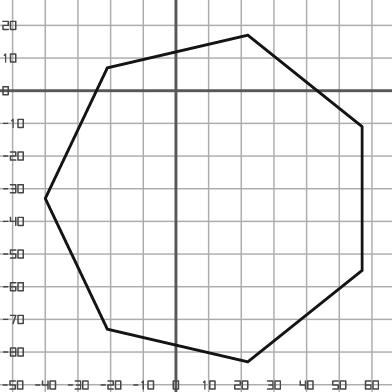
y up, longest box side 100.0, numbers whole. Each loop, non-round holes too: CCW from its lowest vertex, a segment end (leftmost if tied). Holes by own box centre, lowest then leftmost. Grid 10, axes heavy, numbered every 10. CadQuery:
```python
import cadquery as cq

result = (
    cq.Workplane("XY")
    .moveTo(22.0, -83.0)
    .lineTo(57.0, -55.0)
    .lineTo(57.0, -11.0)
    .lineTo(22.0, 17.0)
    .lineTo(-21.0, 7.0)
    .lineTo(-40.0, -33.0)
    .lineTo(-21.0, -73.0)
    .close()
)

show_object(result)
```